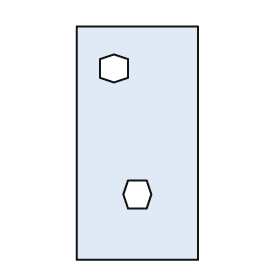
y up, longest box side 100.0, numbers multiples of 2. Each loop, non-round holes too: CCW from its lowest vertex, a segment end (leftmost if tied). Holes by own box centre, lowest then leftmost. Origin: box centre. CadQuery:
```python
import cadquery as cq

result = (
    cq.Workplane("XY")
    .moveTo(-26.0, -50.0)
    .lineTo(26.0, -50.0)
    .lineTo(26.0, 50.0)
    .lineTo(-26.0, 50.0)
    .close()
    .moveTo(-4.0, -28.0)
    .lineTo(4.0, -28.0)
    .lineTo(6.0, -22.0)
    .lineTo(4.0, -16.0)
    .lineTo(-4.0, -16.0)
    .lineTo(-6.0, -22.0)
    .close()
    .moveTo(-10.0, 26.0)
    .lineTo(-4.0, 28.0)
    .lineTo(-4.0, 36.0)
    .lineTo(-10.0, 38.0)
    .lineTo(-16.0, 36.0)
    .lineTo(-16.0, 28.0)
    .close()
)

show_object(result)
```